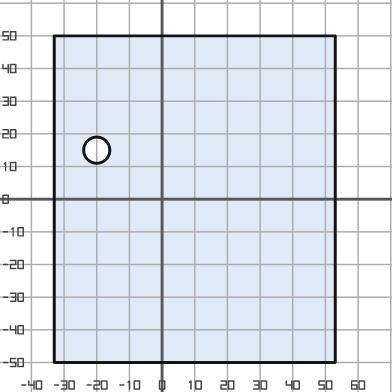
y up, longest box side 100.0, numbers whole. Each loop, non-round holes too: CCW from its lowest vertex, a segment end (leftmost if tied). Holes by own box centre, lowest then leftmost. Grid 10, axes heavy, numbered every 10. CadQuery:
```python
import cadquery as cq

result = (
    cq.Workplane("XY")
    .moveTo(-33.0, -50.0)
    .lineTo(53.0, -50.0)
    .lineTo(53.0, 50.0)
    .lineTo(-33.0, 50.0)
    .close()
    .moveTo(-20.0, 15.0)
    .circle(4.0)
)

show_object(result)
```